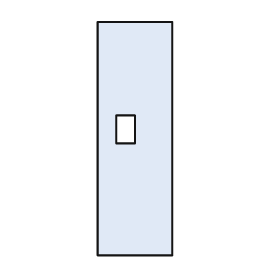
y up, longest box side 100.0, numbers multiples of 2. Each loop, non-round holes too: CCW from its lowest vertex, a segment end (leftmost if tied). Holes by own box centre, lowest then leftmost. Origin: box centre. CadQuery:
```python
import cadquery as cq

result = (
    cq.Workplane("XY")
    .moveTo(-16.0, -50.0)
    .lineTo(16.0, -50.0)
    .lineTo(16.0, 50.0)
    .lineTo(-16.0, 50.0)
    .close()
    .moveTo(-8.0, -2.0)
    .lineTo(0.0, -2.0)
    .lineTo(0.0, 10.0)
    .lineTo(-8.0, 10.0)
    .close()
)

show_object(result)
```